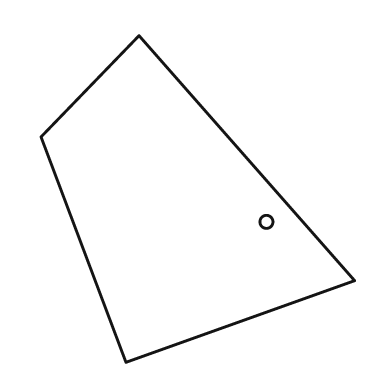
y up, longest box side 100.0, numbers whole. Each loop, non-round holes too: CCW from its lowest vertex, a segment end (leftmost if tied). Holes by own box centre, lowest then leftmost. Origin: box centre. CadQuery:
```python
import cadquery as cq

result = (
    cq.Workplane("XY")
    .moveTo(-22.0, -50.0)
    .lineTo(48.0, -25.0)
    .lineTo(-18.0, 50.0)
    .lineTo(-48.0, 19.0)
    .close()
    .moveTo(21.0, -7.0)
    .circle(2.0)
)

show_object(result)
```